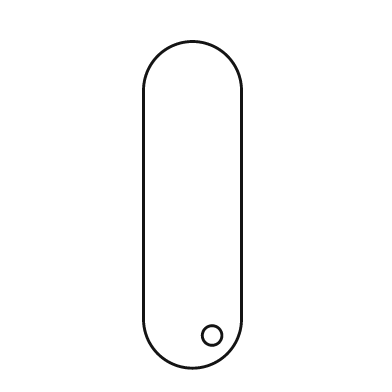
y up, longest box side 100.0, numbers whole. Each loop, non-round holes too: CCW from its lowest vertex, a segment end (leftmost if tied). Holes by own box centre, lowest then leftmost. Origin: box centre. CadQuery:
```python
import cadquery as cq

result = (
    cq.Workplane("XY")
    .moveTo(-15.0, -35.0)
    .threePointArc((0.0, -50.0), (15.0, -35.0))
    .lineTo(15.0, 35.0)
    .threePointArc((0.0, 50.0), (-15.0, 35.0))
    .close()
    .moveTo(6.0, -40.0)
    .circle(3.0)
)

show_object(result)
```